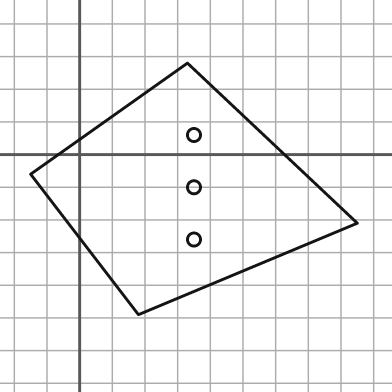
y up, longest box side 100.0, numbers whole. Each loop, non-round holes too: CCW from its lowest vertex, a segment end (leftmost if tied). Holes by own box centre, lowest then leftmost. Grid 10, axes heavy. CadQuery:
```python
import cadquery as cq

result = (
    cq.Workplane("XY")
    .moveTo(18.0, -49.0)
    .lineTo(85.0, -21.0)
    .lineTo(33.0, 28.0)
    .lineTo(-15.0, -6.0)
    .close()
    .moveTo(35.0, -26.0)
    .circle(2.0)
    .moveTo(35.0, -10.0)
    .circle(2.0)
    .moveTo(35.0, 6.0)
    .circle(2.0)
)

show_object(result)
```